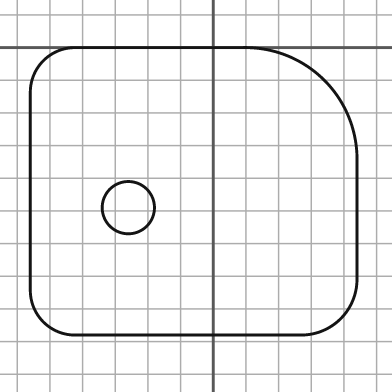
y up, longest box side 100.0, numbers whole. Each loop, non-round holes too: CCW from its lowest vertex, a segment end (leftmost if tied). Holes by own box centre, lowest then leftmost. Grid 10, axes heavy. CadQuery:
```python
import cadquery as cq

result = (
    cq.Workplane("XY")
    .moveTo(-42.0, -88.0)
    .lineTo(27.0, -88.0)
    .threePointArc((39.0, -83.0), (44.0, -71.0))
    .lineTo(44.0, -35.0)
    .threePointArc((34.0, -10.0), (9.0, 0.0))
    .lineTo(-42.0, 0.0)
    .threePointArc((-52.0, -4.0), (-56.0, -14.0))
    .lineTo(-56.0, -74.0)
    .threePointArc((-52.0, -84.0), (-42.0, -88.0))
    .close()
    .moveTo(-26.0, -49.0)
    .circle(8.0)
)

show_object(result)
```